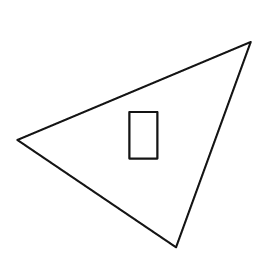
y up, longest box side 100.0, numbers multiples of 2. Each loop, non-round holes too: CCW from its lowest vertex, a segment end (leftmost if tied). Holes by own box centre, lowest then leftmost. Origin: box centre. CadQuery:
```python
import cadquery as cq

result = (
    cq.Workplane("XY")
    .moveTo(18.0, -44.0)
    .lineTo(50.0, 44.0)
    .lineTo(-50.0, 2.0)
    .close()
    .moveTo(-2.0, -6.0)
    .lineTo(10.0, -6.0)
    .lineTo(10.0, 14.0)
    .lineTo(-2.0, 14.0)
    .close()
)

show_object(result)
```